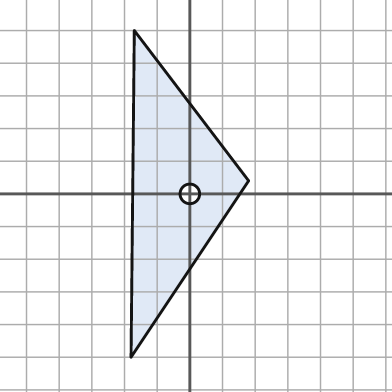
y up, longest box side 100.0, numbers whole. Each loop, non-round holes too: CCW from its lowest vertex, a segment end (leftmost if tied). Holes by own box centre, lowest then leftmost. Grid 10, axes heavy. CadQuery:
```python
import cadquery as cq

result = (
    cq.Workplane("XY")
    .moveTo(-18.0, -50.0)
    .lineTo(18.0, 4.0)
    .lineTo(-17.0, 50.0)
    .close()
    .moveTo(0.0, 0.0)
    .circle(3.0)
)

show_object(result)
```